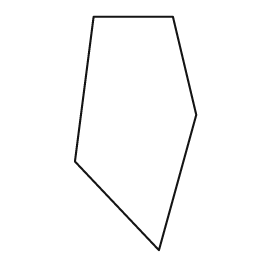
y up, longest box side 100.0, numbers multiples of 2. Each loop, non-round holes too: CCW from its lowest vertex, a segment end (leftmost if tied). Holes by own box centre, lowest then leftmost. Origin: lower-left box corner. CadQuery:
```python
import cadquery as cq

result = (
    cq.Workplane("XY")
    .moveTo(36.0, 0.0)
    .lineTo(52.0, 58.0)
    .lineTo(42.0, 100.0)
    .lineTo(8.0, 100.0)
    .lineTo(0.0, 38.0)
    .close()
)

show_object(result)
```